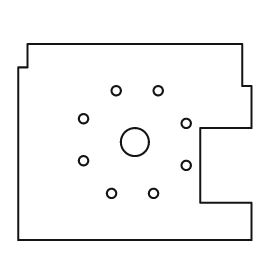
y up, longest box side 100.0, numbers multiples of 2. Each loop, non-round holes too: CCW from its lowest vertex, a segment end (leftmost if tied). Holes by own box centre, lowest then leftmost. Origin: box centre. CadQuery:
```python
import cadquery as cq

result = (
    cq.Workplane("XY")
    .moveTo(-50.0, -42.0)
    .lineTo(50.0, -42.0)
    .lineTo(50.0, -26.0)
    .lineTo(28.0, -26.0)
    .lineTo(28.0, 6.0)
    .lineTo(50.0, 6.0)
    .lineTo(50.0, 24.0)
    .lineTo(46.0, 24.0)
    .lineTo(46.0, 42.0)
    .lineTo(-46.0, 42.0)
    .lineTo(-46.0, 32.0)
    .lineTo(-50.0, 32.0)
    .close()
    .moveTo(-10.0, -22.0)
    .circle(2.0)
    .moveTo(8.0, -22.0)
    .circle(2.0)
    .moveTo(22.0, -10.0)
    .circle(2.0)
    .moveTo(-22.0, -8.0)
    .circle(2.0)
    .moveTo(0.0, 0.0)
    .circle(6.0)
    .moveTo(22.0, 8.0)
    .circle(2.0)
    .moveTo(-22.0, 10.0)
    .circle(2.0)
    .moveTo(-8.0, 22.0)
    .circle(2.0)
    .moveTo(10.0, 22.0)
    .circle(2.0)
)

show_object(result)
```